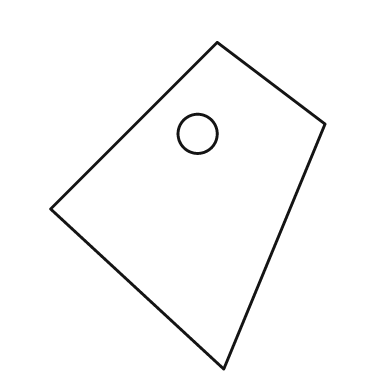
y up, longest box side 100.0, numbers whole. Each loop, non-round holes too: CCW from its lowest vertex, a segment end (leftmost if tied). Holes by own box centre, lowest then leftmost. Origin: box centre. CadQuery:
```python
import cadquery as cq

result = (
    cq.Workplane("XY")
    .moveTo(11.0, -50.0)
    .lineTo(42.0, 25.0)
    .lineTo(9.0, 50.0)
    .lineTo(-42.0, -1.0)
    .close()
    .moveTo(3.0, 22.0)
    .circle(6.0)
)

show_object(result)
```